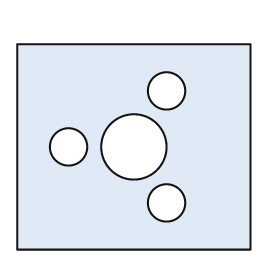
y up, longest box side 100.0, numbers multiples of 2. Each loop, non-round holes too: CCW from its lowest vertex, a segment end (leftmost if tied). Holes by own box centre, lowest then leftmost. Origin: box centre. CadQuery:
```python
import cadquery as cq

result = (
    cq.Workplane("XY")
    .moveTo(-50.0, -44.0)
    .lineTo(50.0, -44.0)
    .lineTo(50.0, 44.0)
    .lineTo(-50.0, 44.0)
    .close()
    .moveTo(14.0, -24.0)
    .circle(8.0)
    .moveTo(-28.0, 0.0)
    .circle(8.0)
    .moveTo(0.0, 0.0)
    .circle(14.0)
    .moveTo(14.0, 24.0)
    .circle(8.0)
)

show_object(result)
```